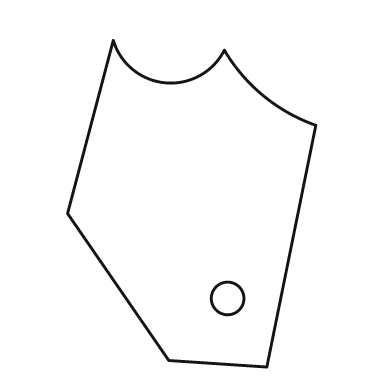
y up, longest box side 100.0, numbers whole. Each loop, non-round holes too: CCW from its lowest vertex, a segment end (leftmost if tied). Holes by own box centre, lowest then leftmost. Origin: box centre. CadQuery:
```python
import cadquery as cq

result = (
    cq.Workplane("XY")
    .moveTo(23.0, -50.0)
    .lineTo(38.0, 24.0)
    .threePointArc((22.0, 33.0), (10.0, 47.0))
    .threePointArc((-8.0, 37.0), (-24.0, 50.0))
    .lineTo(-38.0, -3.0)
    .lineTo(-7.0, -48.0)
    .close()
    .moveTo(11.0, -29.0)
    .circle(5.0)
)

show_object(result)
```